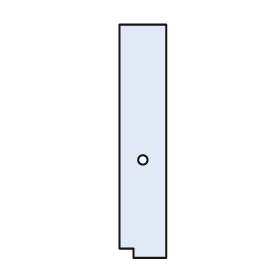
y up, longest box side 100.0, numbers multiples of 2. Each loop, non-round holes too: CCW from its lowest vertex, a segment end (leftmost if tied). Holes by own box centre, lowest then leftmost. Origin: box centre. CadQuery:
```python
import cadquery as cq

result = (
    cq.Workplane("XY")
    .moveTo(-4.0, -50.0)
    .lineTo(10.0, -50.0)
    .lineTo(10.0, 50.0)
    .lineTo(-10.0, 50.0)
    .lineTo(-10.0, -46.0)
    .lineTo(-4.0, -46.0)
    .close()
    .moveTo(0.0, -8.0)
    .circle(2.0)
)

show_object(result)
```